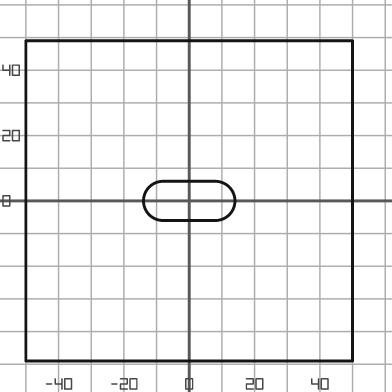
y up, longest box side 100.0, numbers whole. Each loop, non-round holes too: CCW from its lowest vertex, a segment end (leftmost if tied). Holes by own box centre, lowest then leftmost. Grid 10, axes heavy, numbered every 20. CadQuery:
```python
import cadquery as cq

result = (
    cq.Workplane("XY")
    .moveTo(-50.0, -49.0)
    .lineTo(50.0, -49.0)
    .lineTo(50.0, 49.0)
    .lineTo(-50.0, 49.0)
    .close()
    .moveTo(-8.0, -6.0)
    .lineTo(8.0, -6.0)
    .threePointArc((14.0, 0.0), (8.0, 6.0))
    .lineTo(-8.0, 6.0)
    .threePointArc((-14.0, 0.0), (-8.0, -6.0))
    .close()
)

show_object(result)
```